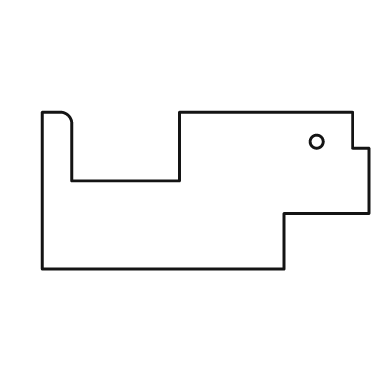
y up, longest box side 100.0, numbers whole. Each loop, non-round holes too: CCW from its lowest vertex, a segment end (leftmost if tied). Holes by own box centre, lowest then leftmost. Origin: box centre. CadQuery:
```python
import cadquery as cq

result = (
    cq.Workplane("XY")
    .moveTo(-50.0, -24.0)
    .lineTo(24.0, -24.0)
    .lineTo(24.0, -7.0)
    .lineTo(50.0, -7.0)
    .lineTo(50.0, 13.0)
    .lineTo(45.0, 13.0)
    .lineTo(45.0, 24.0)
    .lineTo(-8.0, 24.0)
    .lineTo(-8.0, 3.0)
    .lineTo(-41.0, 3.0)
    .lineTo(-41.0, 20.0)
    .threePointArc((-42.0, 23.0), (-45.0, 24.0))
    .lineTo(-50.0, 24.0)
    .close()
    .moveTo(34.0, 15.0)
    .circle(2.0)
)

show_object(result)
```